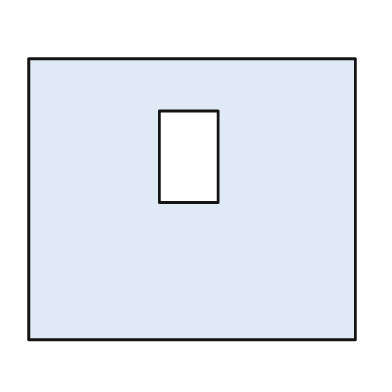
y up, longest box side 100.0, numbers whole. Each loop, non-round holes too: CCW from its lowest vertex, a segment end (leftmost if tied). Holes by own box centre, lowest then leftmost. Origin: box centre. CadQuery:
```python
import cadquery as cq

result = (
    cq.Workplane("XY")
    .moveTo(-50.0, -43.0)
    .lineTo(50.0, -43.0)
    .lineTo(50.0, 43.0)
    .lineTo(-50.0, 43.0)
    .close()
    .moveTo(-10.0, -1.0)
    .lineTo(8.0, -1.0)
    .lineTo(8.0, 27.0)
    .lineTo(-10.0, 27.0)
    .close()
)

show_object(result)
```